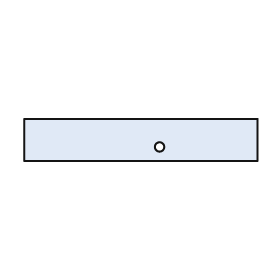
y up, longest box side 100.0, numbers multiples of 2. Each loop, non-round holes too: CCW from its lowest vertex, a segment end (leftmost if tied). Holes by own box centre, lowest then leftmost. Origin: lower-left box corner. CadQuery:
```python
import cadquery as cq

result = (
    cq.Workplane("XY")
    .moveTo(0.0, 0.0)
    .lineTo(100.0, 0.0)
    .lineTo(100.0, 18.0)
    .lineTo(0.0, 18.0)
    .close()
    .moveTo(58.0, 6.0)
    .circle(2.0)
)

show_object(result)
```